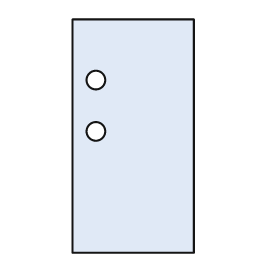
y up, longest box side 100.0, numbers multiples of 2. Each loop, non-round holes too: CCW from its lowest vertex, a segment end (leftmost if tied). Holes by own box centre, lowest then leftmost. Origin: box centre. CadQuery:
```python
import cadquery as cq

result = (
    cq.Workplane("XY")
    .moveTo(-26.0, -50.0)
    .lineTo(26.0, -50.0)
    .lineTo(26.0, 50.0)
    .lineTo(-26.0, 50.0)
    .close()
    .moveTo(-16.0, 2.0)
    .circle(4.0)
    .moveTo(-16.0, 24.0)
    .circle(4.0)
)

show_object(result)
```